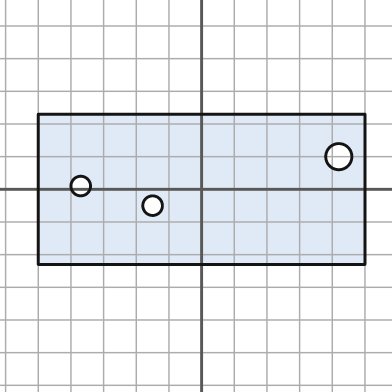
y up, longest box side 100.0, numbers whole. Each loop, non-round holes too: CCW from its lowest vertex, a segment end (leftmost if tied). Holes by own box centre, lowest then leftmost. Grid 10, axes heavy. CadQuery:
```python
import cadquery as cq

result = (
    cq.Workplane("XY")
    .moveTo(-50.0, -23.0)
    .lineTo(50.0, -23.0)
    .lineTo(50.0, 23.0)
    .lineTo(-50.0, 23.0)
    .close()
    .moveTo(-15.0, -5.0)
    .circle(3.0)
    .moveTo(-37.0, 1.0)
    .circle(3.0)
    .moveTo(42.0, 10.0)
    .circle(4.0)
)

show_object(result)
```